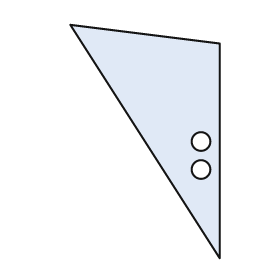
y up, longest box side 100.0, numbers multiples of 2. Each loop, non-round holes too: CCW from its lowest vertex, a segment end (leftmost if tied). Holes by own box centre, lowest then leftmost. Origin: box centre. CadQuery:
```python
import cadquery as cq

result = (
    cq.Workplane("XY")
    .moveTo(32.0, -50.0)
    .lineTo(32.0, 42.0)
    .lineTo(-32.0, 50.0)
    .close()
    .moveTo(24.0, -12.0)
    .circle(4.0)
    .moveTo(24.0, 0.0)
    .circle(4.0)
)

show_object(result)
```